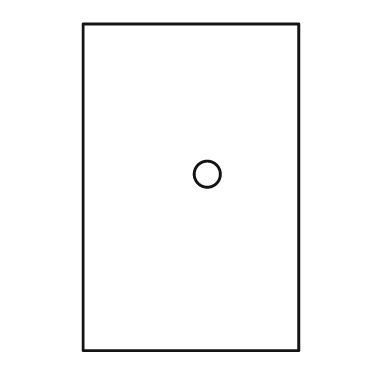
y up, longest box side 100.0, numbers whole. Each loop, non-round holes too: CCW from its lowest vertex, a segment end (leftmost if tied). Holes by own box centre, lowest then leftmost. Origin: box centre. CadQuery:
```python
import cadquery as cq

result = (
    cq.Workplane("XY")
    .moveTo(-33.0, -50.0)
    .lineTo(33.0, -50.0)
    .lineTo(33.0, 50.0)
    .lineTo(-33.0, 50.0)
    .close()
    .moveTo(5.0, 4.0)
    .circle(4.0)
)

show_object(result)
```